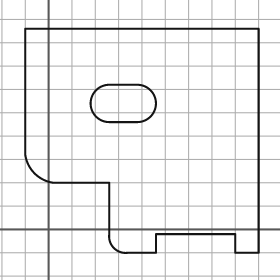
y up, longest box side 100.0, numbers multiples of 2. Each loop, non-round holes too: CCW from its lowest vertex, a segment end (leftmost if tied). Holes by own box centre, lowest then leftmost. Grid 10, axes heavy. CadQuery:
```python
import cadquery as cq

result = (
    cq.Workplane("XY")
    .moveTo(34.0, -10.0)
    .lineTo(46.0, -10.0)
    .lineTo(46.0, -2.0)
    .lineTo(80.0, -2.0)
    .lineTo(80.0, -10.0)
    .lineTo(90.0, -10.0)
    .lineTo(90.0, 86.0)
    .lineTo(-10.0, 86.0)
    .lineTo(-10.0, 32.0)
    .threePointArc((-6.0, 24.0), (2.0, 20.0))
    .lineTo(26.0, 20.0)
    .lineTo(26.0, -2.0)
    .threePointArc((28.0, -8.0), (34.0, -10.0))
    .close()
    .moveTo(26.0, 46.0)
    .lineTo(38.0, 46.0)
    .threePointArc((46.0, 54.0), (38.0, 62.0))
    .lineTo(26.0, 62.0)
    .threePointArc((18.0, 54.0), (26.0, 46.0))
    .close()
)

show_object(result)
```